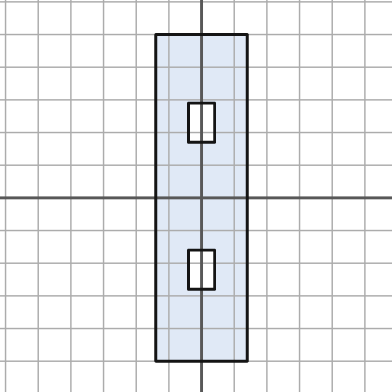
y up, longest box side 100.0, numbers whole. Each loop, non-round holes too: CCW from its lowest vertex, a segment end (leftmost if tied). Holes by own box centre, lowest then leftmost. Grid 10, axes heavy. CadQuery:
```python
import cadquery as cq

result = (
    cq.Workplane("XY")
    .moveTo(-14.0, -50.0)
    .lineTo(14.0, -50.0)
    .lineTo(14.0, 50.0)
    .lineTo(-14.0, 50.0)
    .close()
    .moveTo(-4.0, -28.0)
    .lineTo(4.0, -28.0)
    .lineTo(4.0, -16.0)
    .lineTo(-4.0, -16.0)
    .close()
    .moveTo(-4.0, 17.0)
    .lineTo(4.0, 17.0)
    .lineTo(4.0, 29.0)
    .lineTo(-4.0, 29.0)
    .close()
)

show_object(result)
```